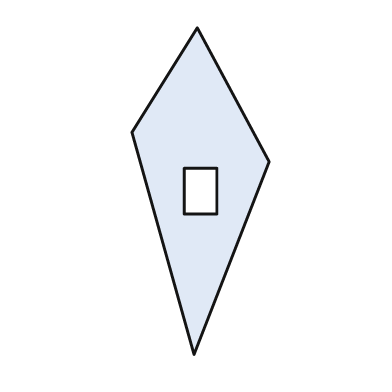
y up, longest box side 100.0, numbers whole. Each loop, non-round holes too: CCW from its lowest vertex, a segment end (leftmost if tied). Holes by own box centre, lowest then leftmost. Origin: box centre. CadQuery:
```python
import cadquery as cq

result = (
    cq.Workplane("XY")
    .moveTo(-2.0, -50.0)
    .lineTo(21.0, 9.0)
    .lineTo(-1.0, 50.0)
    .lineTo(-21.0, 18.0)
    .close()
    .moveTo(-5.0, -7.0)
    .lineTo(5.0, -7.0)
    .lineTo(5.0, 7.0)
    .lineTo(-5.0, 7.0)
    .close()
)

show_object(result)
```